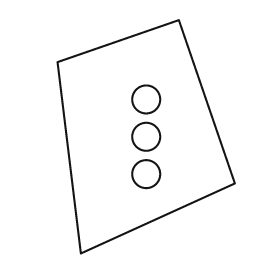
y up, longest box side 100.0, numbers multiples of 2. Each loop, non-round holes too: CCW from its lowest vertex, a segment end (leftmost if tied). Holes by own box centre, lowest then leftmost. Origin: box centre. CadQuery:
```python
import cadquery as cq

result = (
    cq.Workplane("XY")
    .moveTo(-28.0, -50.0)
    .lineTo(38.0, -20.0)
    .lineTo(14.0, 50.0)
    .lineTo(-38.0, 32.0)
    .close()
    .moveTo(0.0, -16.0)
    .circle(6.0)
    .moveTo(0.0, 0.0)
    .circle(6.0)
    .moveTo(0.0, 16.0)
    .circle(6.0)
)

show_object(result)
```